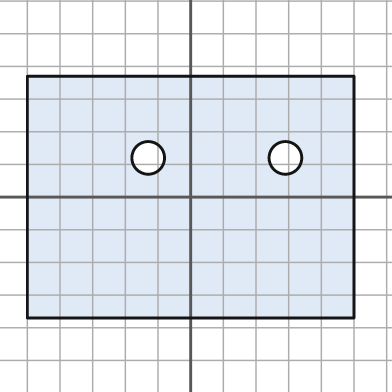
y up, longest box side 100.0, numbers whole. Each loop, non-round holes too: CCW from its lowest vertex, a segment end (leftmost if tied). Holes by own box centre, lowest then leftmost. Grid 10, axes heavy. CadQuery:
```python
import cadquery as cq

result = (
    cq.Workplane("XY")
    .moveTo(-50.0, -37.0)
    .lineTo(50.0, -37.0)
    .lineTo(50.0, 37.0)
    .lineTo(-50.0, 37.0)
    .close()
    .moveTo(-13.0, 12.0)
    .circle(5.0)
    .moveTo(29.0, 12.0)
    .circle(5.0)
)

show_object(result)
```